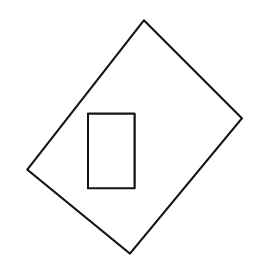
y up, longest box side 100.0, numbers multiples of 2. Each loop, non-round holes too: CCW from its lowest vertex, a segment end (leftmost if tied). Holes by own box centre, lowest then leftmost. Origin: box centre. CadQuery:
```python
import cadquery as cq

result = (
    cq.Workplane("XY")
    .moveTo(-2.0, -50.0)
    .lineTo(46.0, 8.0)
    .lineTo(4.0, 50.0)
    .lineTo(-46.0, -14.0)
    .close()
    .moveTo(-20.0, -22.0)
    .lineTo(0.0, -22.0)
    .lineTo(0.0, 10.0)
    .lineTo(-20.0, 10.0)
    .close()
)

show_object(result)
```